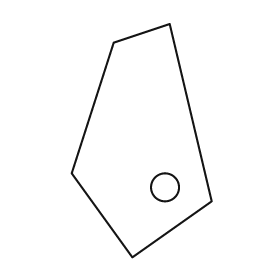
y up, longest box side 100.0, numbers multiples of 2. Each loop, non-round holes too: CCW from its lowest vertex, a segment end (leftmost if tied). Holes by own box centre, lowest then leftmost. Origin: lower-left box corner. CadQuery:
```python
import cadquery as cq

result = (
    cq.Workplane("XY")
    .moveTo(26.0, 0.0)
    .lineTo(60.0, 24.0)
    .lineTo(42.0, 100.0)
    .lineTo(18.0, 92.0)
    .lineTo(0.0, 36.0)
    .close()
    .moveTo(40.0, 30.0)
    .circle(6.0)
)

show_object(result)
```